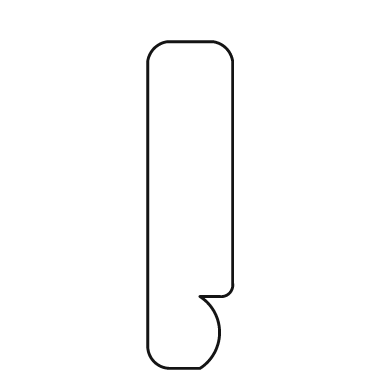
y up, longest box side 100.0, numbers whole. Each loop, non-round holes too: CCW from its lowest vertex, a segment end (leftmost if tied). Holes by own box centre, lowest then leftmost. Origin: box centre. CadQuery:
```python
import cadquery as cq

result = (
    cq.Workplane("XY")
    .moveTo(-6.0, -50.0)
    .lineTo(3.0, -50.0)
    .threePointArc((9.0, -39.0), (3.0, -28.0))
    .lineTo(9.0, -28.0)
    .threePointArc((12.0, -27.0), (13.0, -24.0))
    .lineTo(13.0, 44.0)
    .threePointArc((11.0, 48.0), (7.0, 50.0))
    .lineTo(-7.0, 50.0)
    .threePointArc((-11.0, 48.0), (-13.0, 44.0))
    .lineTo(-13.0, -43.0)
    .threePointArc((-11.0, -48.0), (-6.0, -50.0))
    .close()
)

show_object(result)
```